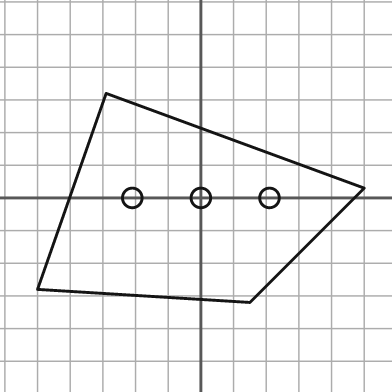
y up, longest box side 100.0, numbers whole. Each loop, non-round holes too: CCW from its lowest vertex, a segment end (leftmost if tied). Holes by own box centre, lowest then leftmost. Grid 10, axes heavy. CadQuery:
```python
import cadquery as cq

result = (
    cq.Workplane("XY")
    .moveTo(15.0, -32.0)
    .lineTo(50.0, 3.0)
    .lineTo(-29.0, 32.0)
    .lineTo(-50.0, -28.0)
    .close()
    .moveTo(-21.0, 0.0)
    .circle(3.0)
    .moveTo(0.0, 0.0)
    .circle(3.0)
    .moveTo(21.0, 0.0)
    .circle(3.0)
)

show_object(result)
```